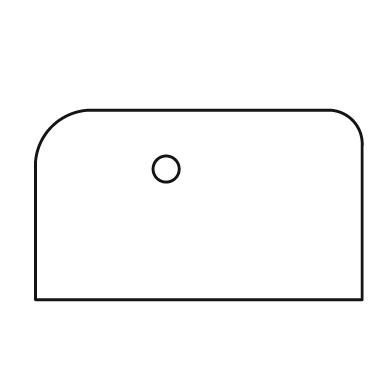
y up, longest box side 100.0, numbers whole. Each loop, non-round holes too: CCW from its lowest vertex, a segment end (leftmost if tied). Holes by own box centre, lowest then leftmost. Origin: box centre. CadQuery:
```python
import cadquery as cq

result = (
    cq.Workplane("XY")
    .moveTo(-50.0, -29.0)
    .lineTo(50.0, -29.0)
    .lineTo(50.0, 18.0)
    .threePointArc((47.0, 26.0), (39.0, 29.0))
    .lineTo(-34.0, 29.0)
    .threePointArc((-45.0, 24.0), (-50.0, 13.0))
    .close()
    .moveTo(-10.0, 11.0)
    .circle(4.0)
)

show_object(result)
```